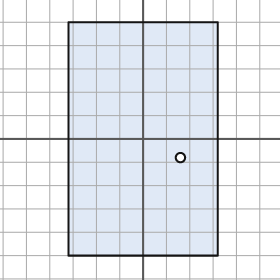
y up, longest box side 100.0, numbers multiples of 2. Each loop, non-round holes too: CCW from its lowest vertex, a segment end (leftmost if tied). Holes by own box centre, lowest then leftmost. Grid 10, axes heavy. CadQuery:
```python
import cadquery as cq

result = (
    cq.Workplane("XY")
    .moveTo(-32.0, -50.0)
    .lineTo(32.0, -50.0)
    .lineTo(32.0, 50.0)
    .lineTo(-32.0, 50.0)
    .close()
    .moveTo(16.0, -8.0)
    .circle(2.0)
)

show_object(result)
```